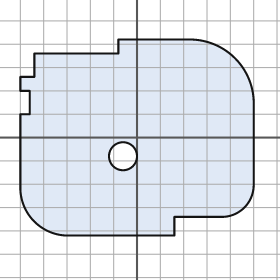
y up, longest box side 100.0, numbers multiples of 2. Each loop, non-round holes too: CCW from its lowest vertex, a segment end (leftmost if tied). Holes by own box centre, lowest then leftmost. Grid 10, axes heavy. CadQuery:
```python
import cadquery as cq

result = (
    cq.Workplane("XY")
    .moveTo(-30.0, -42.0)
    .lineTo(16.0, -42.0)
    .lineTo(16.0, -34.0)
    .lineTo(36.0, -34.0)
    .threePointArc((46.0, -30.0), (50.0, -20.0))
    .lineTo(50.0, 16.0)
    .threePointArc((42.0, 34.0), (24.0, 42.0))
    .lineTo(-8.0, 42.0)
    .lineTo(-8.0, 36.0)
    .lineTo(-44.0, 36.0)
    .lineTo(-44.0, 26.0)
    .lineTo(-50.0, 26.0)
    .lineTo(-50.0, 20.0)
    .lineTo(-46.0, 20.0)
    .lineTo(-46.0, 10.0)
    .lineTo(-50.0, 10.0)
    .lineTo(-50.0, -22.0)
    .threePointArc((-44.0, -36.0), (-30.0, -42.0))
    .close()
    .moveTo(-6.0, -8.0)
    .circle(6.0)
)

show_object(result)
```